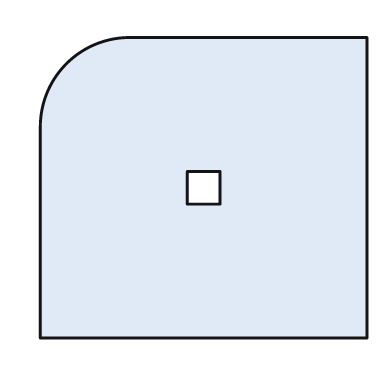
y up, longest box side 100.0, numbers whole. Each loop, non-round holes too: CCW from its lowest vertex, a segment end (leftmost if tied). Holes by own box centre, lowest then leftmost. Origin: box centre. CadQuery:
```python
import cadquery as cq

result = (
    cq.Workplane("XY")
    .moveTo(-50.0, -46.0)
    .lineTo(50.0, -46.0)
    .lineTo(50.0, 46.0)
    .lineTo(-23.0, 46.0)
    .threePointArc((-42.0, 38.0), (-50.0, 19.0))
    .close()
    .moveTo(-5.0, -5.0)
    .lineTo(5.0, -5.0)
    .lineTo(5.0, 5.0)
    .lineTo(-5.0, 5.0)
    .close()
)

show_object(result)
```